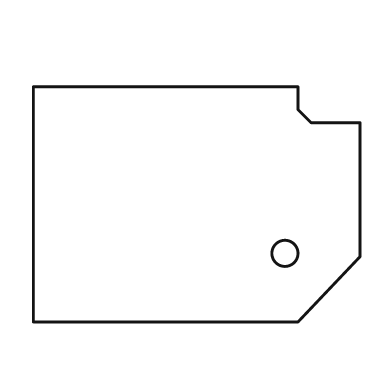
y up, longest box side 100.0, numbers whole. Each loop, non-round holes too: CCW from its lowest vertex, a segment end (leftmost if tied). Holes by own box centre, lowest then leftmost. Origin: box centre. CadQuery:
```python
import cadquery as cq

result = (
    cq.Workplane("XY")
    .moveTo(-50.0, -36.0)
    .lineTo(31.0, -36.0)
    .lineTo(50.0, -16.0)
    .lineTo(50.0, 25.0)
    .lineTo(35.0, 25.0)
    .lineTo(31.0, 29.0)
    .lineTo(31.0, 36.0)
    .lineTo(-50.0, 36.0)
    .close()
    .moveTo(27.0, -15.0)
    .circle(4.0)
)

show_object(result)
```